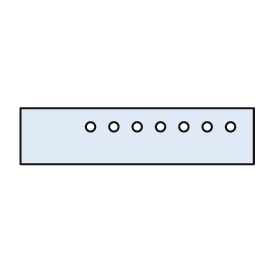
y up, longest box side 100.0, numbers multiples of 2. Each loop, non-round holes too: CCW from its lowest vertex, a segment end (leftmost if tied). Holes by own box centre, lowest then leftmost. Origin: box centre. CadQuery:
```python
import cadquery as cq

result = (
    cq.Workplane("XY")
    .moveTo(-50.0, -12.0)
    .lineTo(50.0, -12.0)
    .lineTo(50.0, 12.0)
    .lineTo(-50.0, 12.0)
    .close()
    .moveTo(-20.0, 4.0)
    .circle(2.0)
    .moveTo(-10.0, 4.0)
    .circle(2.0)
    .moveTo(0.0, 4.0)
    .circle(2.0)
    .moveTo(10.0, 4.0)
    .circle(2.0)
    .moveTo(20.0, 4.0)
    .circle(2.0)
    .moveTo(30.0, 4.0)
    .circle(2.0)
    .moveTo(40.0, 4.0)
    .circle(2.0)
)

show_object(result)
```